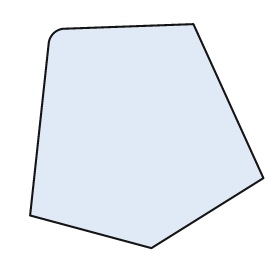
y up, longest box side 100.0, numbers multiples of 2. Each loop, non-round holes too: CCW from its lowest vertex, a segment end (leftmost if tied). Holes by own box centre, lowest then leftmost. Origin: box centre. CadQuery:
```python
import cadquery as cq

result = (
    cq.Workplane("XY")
    .moveTo(2.0, -48.0)
    .lineTo(50.0, -18.0)
    .lineTo(20.0, 48.0)
    .lineTo(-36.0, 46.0)
    .threePointArc((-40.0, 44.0), (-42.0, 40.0))
    .lineTo(-50.0, -34.0)
    .close()
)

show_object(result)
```